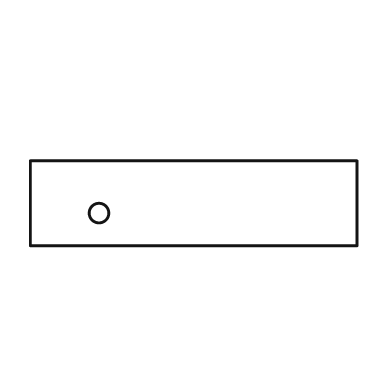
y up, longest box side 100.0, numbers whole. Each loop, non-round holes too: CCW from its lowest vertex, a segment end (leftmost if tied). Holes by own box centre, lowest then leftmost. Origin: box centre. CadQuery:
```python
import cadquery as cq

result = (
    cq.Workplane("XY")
    .moveTo(-50.0, -13.0)
    .lineTo(50.0, -13.0)
    .lineTo(50.0, 13.0)
    .lineTo(-50.0, 13.0)
    .close()
    .moveTo(-29.0, -3.0)
    .circle(3.0)
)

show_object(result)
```